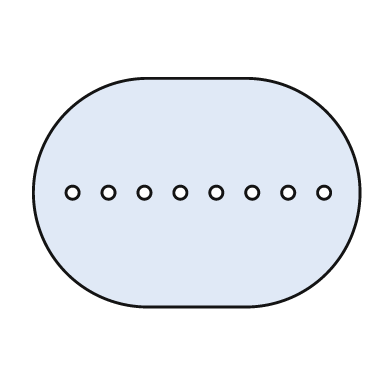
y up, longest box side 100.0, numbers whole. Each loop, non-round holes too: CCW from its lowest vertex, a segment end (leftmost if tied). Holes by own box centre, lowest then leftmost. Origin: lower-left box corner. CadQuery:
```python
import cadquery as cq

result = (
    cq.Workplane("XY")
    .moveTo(35.0, 0.0)
    .lineTo(65.0, 0.0)
    .threePointArc((100.0, 35.0), (65.0, 70.0))
    .lineTo(35.0, 70.0)
    .threePointArc((0.0, 35.0), (35.0, 0.0))
    .close()
    .moveTo(12.0, 35.0)
    .circle(2.0)
    .moveTo(23.0, 35.0)
    .circle(2.0)
    .moveTo(34.0, 35.0)
    .circle(2.0)
    .moveTo(45.0, 35.0)
    .circle(2.0)
    .moveTo(56.0, 35.0)
    .circle(2.0)
    .moveTo(67.0, 35.0)
    .circle(2.0)
    .moveTo(78.0, 35.0)
    .circle(2.0)
    .moveTo(89.0, 35.0)
    .circle(2.0)
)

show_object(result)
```